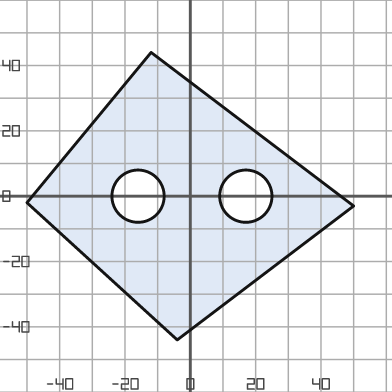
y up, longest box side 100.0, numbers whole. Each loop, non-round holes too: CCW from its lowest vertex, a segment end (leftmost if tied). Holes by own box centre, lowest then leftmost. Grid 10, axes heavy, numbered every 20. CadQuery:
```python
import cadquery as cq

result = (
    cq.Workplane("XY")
    .moveTo(-4.0, -44.0)
    .lineTo(50.0, -3.0)
    .lineTo(-12.0, 44.0)
    .lineTo(-50.0, -2.0)
    .close()
    .moveTo(-16.0, 0.0)
    .circle(8.0)
    .moveTo(17.0, 0.0)
    .circle(8.0)
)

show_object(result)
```